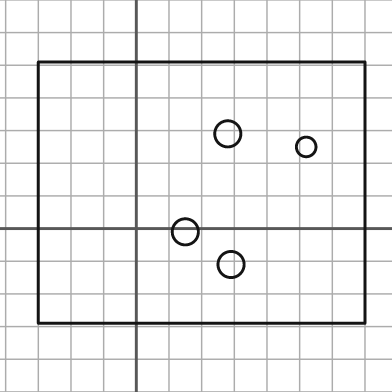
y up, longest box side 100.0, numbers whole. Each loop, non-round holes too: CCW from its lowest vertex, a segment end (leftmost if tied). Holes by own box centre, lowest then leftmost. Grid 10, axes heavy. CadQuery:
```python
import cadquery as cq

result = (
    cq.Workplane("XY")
    .moveTo(-30.0, -29.0)
    .lineTo(70.0, -29.0)
    .lineTo(70.0, 51.0)
    .lineTo(-30.0, 51.0)
    .close()
    .moveTo(29.0, -11.0)
    .circle(4.0)
    .moveTo(15.0, -1.0)
    .circle(4.0)
    .moveTo(52.0, 25.0)
    .circle(3.0)
    .moveTo(28.0, 29.0)
    .circle(4.0)
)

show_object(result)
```